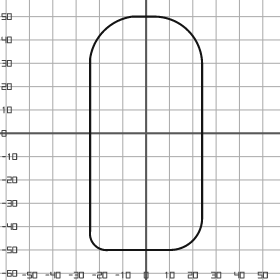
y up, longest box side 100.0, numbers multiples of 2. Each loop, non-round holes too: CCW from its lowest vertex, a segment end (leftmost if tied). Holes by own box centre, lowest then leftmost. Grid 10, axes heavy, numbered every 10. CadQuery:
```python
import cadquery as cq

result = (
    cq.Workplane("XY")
    .moveTo(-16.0, -50.0)
    .lineTo(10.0, -50.0)
    .threePointArc((20.0, -46.0), (24.0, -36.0))
    .lineTo(24.0, 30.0)
    .threePointArc((18.0, 44.0), (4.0, 50.0))
    .lineTo(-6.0, 50.0)
    .threePointArc((-18.0, 44.0), (-24.0, 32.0))
    .lineTo(-24.0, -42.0)
    .threePointArc((-22.0, -48.0), (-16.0, -50.0))
    .close()
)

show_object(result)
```